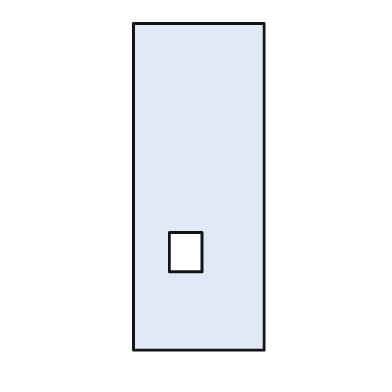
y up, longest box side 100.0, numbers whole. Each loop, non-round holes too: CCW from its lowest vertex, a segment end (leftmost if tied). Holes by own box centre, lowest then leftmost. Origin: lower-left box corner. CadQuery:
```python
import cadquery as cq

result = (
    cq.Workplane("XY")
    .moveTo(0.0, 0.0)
    .lineTo(40.0, 0.0)
    .lineTo(40.0, 100.0)
    .lineTo(0.0, 100.0)
    .close()
    .moveTo(11.0, 24.0)
    .lineTo(21.0, 24.0)
    .lineTo(21.0, 36.0)
    .lineTo(11.0, 36.0)
    .close()
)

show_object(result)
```